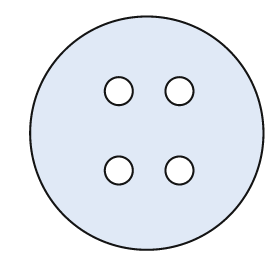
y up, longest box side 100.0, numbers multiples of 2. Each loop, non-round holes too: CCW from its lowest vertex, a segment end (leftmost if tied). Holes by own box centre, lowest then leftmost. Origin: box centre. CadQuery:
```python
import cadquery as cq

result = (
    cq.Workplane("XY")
    .moveTo(0.0, 0.0)
    .circle(50.0)
    .moveTo(-12.0, -16.0)
    .circle(6.0)
    .moveTo(14.0, -16.0)
    .circle(6.0)
    .moveTo(-12.0, 18.0)
    .circle(6.0)
    .moveTo(14.0, 18.0)
    .circle(6.0)
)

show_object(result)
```